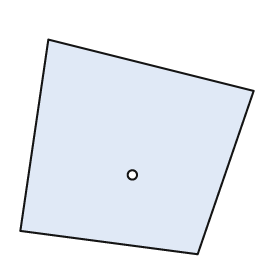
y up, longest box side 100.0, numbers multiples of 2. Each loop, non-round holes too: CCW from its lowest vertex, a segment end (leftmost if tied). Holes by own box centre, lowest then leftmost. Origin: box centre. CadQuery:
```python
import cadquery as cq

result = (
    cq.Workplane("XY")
    .moveTo(26.0, -46.0)
    .lineTo(50.0, 24.0)
    .lineTo(-38.0, 46.0)
    .lineTo(-50.0, -36.0)
    .close()
    .moveTo(-2.0, -12.0)
    .circle(2.0)
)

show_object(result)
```